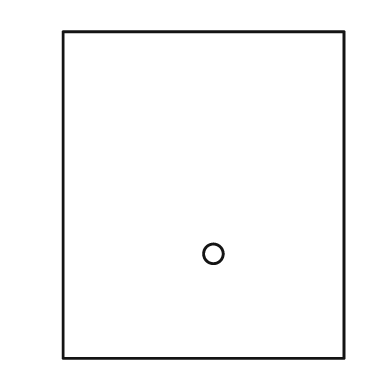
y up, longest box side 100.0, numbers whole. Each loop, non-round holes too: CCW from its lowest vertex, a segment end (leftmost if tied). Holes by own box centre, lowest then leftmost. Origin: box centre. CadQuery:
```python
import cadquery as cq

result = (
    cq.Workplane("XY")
    .moveTo(-43.0, -50.0)
    .lineTo(43.0, -50.0)
    .lineTo(43.0, 50.0)
    .lineTo(-43.0, 50.0)
    .close()
    .moveTo(3.0, -18.0)
    .circle(3.0)
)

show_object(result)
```